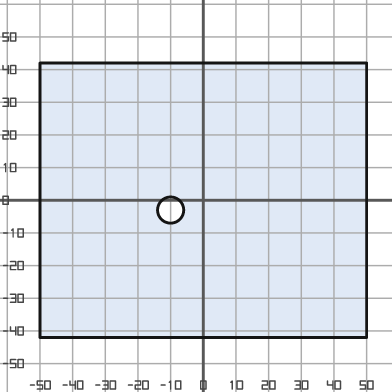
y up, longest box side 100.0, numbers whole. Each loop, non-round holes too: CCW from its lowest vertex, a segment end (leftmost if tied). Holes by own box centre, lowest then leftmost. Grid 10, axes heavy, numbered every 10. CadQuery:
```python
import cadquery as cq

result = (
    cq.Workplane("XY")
    .moveTo(-50.0, -42.0)
    .lineTo(50.0, -42.0)
    .lineTo(50.0, 42.0)
    .lineTo(-50.0, 42.0)
    .close()
    .moveTo(-10.0, -3.0)
    .circle(4.0)
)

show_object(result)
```